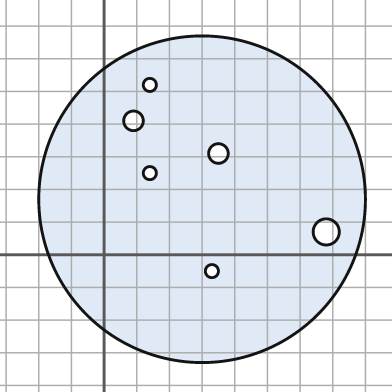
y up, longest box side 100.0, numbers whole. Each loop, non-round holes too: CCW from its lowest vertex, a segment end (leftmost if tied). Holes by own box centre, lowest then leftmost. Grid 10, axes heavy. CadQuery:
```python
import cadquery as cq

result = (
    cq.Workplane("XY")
    .moveTo(30.0, 17.0)
    .circle(50.0)
    .moveTo(33.0, -5.0)
    .circle(2.0)
    .moveTo(68.0, 7.0)
    .circle(4.0)
    .moveTo(14.0, 25.0)
    .circle(2.0)
    .moveTo(35.0, 31.0)
    .circle(3.0)
    .moveTo(9.0, 41.0)
    .circle(3.0)
    .moveTo(14.0, 52.0)
    .circle(2.0)
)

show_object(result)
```